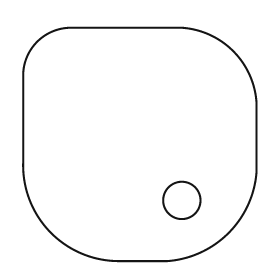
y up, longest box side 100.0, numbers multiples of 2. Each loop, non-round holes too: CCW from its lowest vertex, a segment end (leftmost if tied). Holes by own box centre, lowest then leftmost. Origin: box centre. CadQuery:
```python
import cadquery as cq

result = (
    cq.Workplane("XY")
    .moveTo(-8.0, -50.0)
    .lineTo(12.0, -50.0)
    .threePointArc((38.0, -38.0), (50.0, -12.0))
    .lineTo(50.0, 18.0)
    .threePointArc((40.0, 40.0), (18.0, 50.0))
    .lineTo(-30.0, 50.0)
    .threePointArc((-44.0, 44.0), (-50.0, 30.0))
    .lineTo(-50.0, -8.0)
    .threePointArc((-38.0, -38.0), (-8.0, -50.0))
    .close()
    .moveTo(18.0, -24.0)
    .circle(8.0)
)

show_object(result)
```